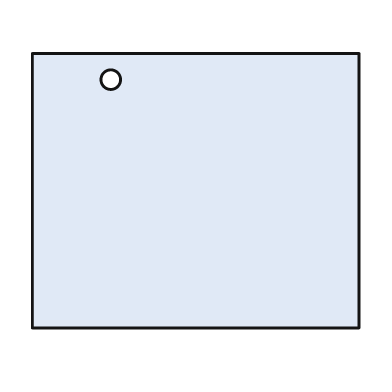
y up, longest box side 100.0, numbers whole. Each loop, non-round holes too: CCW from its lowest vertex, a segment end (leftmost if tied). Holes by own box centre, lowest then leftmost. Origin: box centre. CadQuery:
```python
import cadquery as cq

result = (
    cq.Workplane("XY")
    .moveTo(-50.0, -42.0)
    .lineTo(50.0, -42.0)
    .lineTo(50.0, 42.0)
    .lineTo(-50.0, 42.0)
    .close()
    .moveTo(-26.0, 34.0)
    .circle(3.0)
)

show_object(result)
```